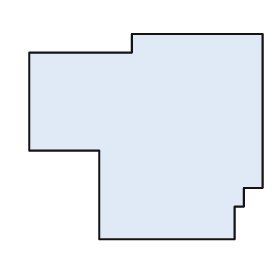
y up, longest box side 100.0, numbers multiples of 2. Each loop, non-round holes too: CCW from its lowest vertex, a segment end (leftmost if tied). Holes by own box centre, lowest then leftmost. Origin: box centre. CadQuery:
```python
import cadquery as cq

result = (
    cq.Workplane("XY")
    .moveTo(-20.0, -44.0)
    .lineTo(38.0, -44.0)
    .lineTo(38.0, -30.0)
    .lineTo(42.0, -30.0)
    .lineTo(42.0, -22.0)
    .lineTo(50.0, -22.0)
    .lineTo(50.0, 44.0)
    .lineTo(-6.0, 44.0)
    .lineTo(-6.0, 36.0)
    .lineTo(-50.0, 36.0)
    .lineTo(-50.0, -6.0)
    .lineTo(-20.0, -6.0)
    .close()
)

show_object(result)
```